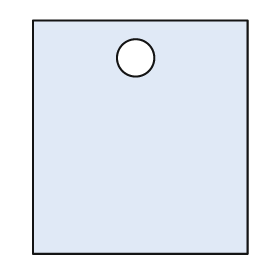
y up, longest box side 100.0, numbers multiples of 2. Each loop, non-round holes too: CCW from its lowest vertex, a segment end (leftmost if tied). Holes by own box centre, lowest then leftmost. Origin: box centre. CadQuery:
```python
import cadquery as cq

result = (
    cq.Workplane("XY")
    .moveTo(-46.0, -50.0)
    .lineTo(46.0, -50.0)
    .lineTo(46.0, 50.0)
    .lineTo(-46.0, 50.0)
    .close()
    .moveTo(-2.0, 34.0)
    .circle(8.0)
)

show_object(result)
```